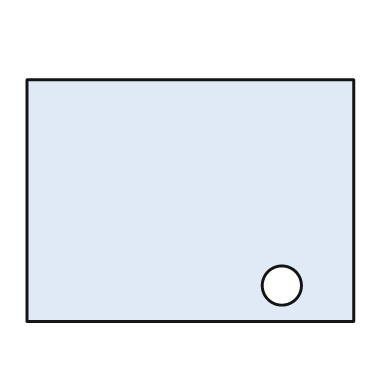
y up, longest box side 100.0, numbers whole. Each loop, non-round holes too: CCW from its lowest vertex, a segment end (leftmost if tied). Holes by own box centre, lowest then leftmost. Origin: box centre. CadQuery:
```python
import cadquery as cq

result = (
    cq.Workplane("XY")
    .moveTo(-50.0, -37.0)
    .lineTo(50.0, -37.0)
    .lineTo(50.0, 37.0)
    .lineTo(-50.0, 37.0)
    .close()
    .moveTo(28.0, -26.0)
    .circle(6.0)
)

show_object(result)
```